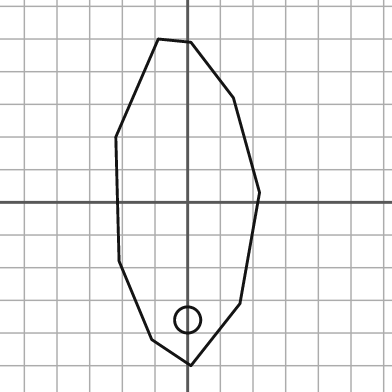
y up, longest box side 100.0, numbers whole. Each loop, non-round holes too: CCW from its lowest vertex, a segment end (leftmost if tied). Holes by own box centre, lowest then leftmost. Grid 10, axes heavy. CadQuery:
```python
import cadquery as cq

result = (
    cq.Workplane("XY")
    .moveTo(1.0, -50.0)
    .lineTo(16.0, -31.0)
    .lineTo(22.0, 3.0)
    .lineTo(14.0, 32.0)
    .lineTo(1.0, 49.0)
    .lineTo(-9.0, 50.0)
    .lineTo(-22.0, 20.0)
    .lineTo(-21.0, -18.0)
    .lineTo(-11.0, -42.0)
    .close()
    .moveTo(0.0, -36.0)
    .circle(4.0)
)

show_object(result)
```